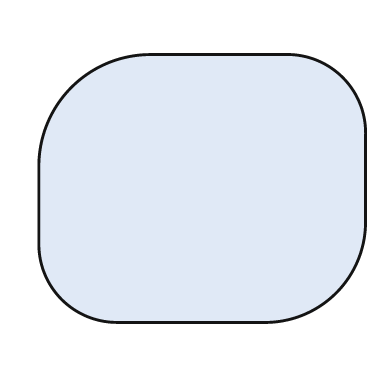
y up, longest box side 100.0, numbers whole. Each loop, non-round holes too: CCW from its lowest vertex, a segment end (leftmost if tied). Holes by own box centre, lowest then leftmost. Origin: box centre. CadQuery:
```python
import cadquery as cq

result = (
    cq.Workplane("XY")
    .moveTo(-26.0, -41.0)
    .lineTo(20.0, -41.0)
    .threePointArc((41.0, -32.0), (50.0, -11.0))
    .lineTo(50.0, 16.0)
    .threePointArc((43.0, 34.0), (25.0, 41.0))
    .lineTo(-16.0, 41.0)
    .threePointArc((-40.0, 31.0), (-50.0, 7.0))
    .lineTo(-50.0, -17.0)
    .threePointArc((-43.0, -34.0), (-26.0, -41.0))
    .close()
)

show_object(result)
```